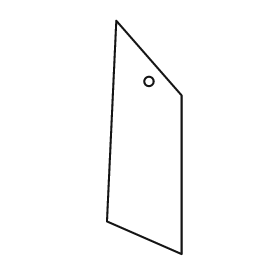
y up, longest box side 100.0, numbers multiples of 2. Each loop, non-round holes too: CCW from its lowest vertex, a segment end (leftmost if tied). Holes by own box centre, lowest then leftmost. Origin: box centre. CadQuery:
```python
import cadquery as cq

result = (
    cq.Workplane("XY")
    .moveTo(16.0, -50.0)
    .lineTo(16.0, 18.0)
    .lineTo(-12.0, 50.0)
    .lineTo(-16.0, -36.0)
    .close()
    .moveTo(2.0, 24.0)
    .circle(2.0)
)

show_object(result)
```